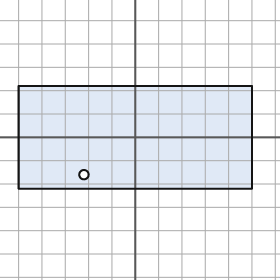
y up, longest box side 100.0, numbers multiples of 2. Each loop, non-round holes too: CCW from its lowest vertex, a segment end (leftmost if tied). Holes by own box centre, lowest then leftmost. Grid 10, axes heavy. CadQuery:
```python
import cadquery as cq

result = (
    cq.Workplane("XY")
    .moveTo(-50.0, -22.0)
    .lineTo(50.0, -22.0)
    .lineTo(50.0, 22.0)
    .lineTo(-50.0, 22.0)
    .close()
    .moveTo(-22.0, -16.0)
    .circle(2.0)
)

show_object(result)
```